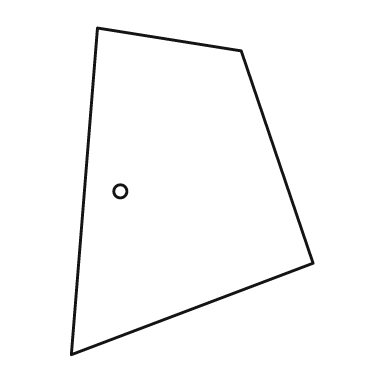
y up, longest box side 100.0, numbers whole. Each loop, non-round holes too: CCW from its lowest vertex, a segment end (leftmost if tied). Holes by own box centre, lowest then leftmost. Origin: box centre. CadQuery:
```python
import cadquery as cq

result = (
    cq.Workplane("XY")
    .moveTo(-37.0, -50.0)
    .lineTo(37.0, -22.0)
    .lineTo(15.0, 43.0)
    .lineTo(-29.0, 50.0)
    .close()
    .moveTo(-22.0, 0.0)
    .circle(2.0)
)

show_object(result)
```